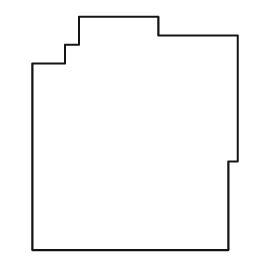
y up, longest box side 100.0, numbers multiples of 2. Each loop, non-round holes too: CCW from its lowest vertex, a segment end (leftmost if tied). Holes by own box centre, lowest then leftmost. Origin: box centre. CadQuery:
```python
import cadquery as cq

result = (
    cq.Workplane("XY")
    .moveTo(-44.0, -50.0)
    .lineTo(40.0, -50.0)
    .lineTo(40.0, -12.0)
    .lineTo(44.0, -12.0)
    .lineTo(44.0, 42.0)
    .lineTo(10.0, 42.0)
    .lineTo(10.0, 50.0)
    .lineTo(-24.0, 50.0)
    .lineTo(-24.0, 38.0)
    .lineTo(-30.0, 38.0)
    .lineTo(-30.0, 30.0)
    .lineTo(-44.0, 30.0)
    .close()
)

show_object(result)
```